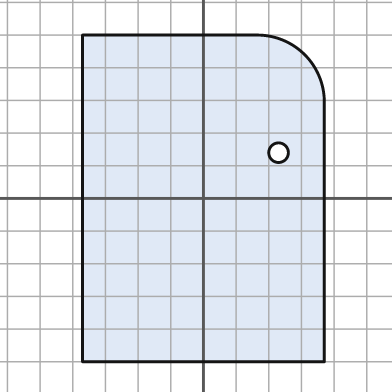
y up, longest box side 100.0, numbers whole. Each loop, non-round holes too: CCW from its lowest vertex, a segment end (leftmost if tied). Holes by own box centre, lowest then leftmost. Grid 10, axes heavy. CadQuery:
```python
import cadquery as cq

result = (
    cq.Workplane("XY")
    .moveTo(-37.0, -50.0)
    .lineTo(37.0, -50.0)
    .lineTo(37.0, 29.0)
    .threePointArc((31.0, 44.0), (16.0, 50.0))
    .lineTo(-37.0, 50.0)
    .close()
    .moveTo(23.0, 14.0)
    .circle(3.0)
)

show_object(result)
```